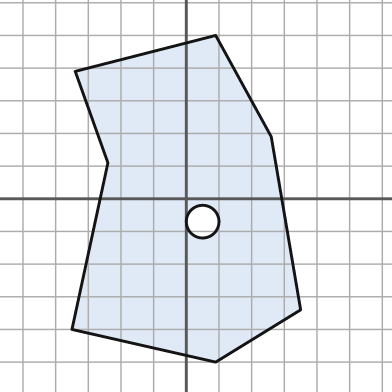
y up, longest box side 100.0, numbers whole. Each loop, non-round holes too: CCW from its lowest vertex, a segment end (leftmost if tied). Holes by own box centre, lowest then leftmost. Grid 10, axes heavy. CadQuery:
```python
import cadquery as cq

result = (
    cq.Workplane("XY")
    .moveTo(9.0, -50.0)
    .lineTo(35.0, -34.0)
    .lineTo(26.0, 19.0)
    .lineTo(9.0, 50.0)
    .lineTo(-34.0, 39.0)
    .lineTo(-24.0, 11.0)
    .lineTo(-35.0, -40.0)
    .close()
    .moveTo(5.0, -7.0)
    .circle(5.0)
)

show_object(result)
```